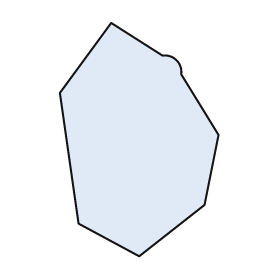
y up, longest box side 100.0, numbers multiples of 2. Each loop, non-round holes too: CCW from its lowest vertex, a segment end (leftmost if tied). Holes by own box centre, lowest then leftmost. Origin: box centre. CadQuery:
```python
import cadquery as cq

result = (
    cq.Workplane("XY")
    .moveTo(0.0, -50.0)
    .lineTo(28.0, -28.0)
    .lineTo(34.0, 2.0)
    .lineTo(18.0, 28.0)
    .threePointArc((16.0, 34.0), (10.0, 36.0))
    .lineTo(-12.0, 50.0)
    .lineTo(-34.0, 20.0)
    .lineTo(-26.0, -36.0)
    .close()
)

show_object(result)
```